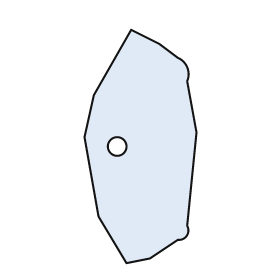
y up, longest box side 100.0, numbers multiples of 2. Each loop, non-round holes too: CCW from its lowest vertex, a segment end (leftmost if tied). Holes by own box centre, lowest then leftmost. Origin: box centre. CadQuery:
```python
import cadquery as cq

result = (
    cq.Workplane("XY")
    .moveTo(-6.0, -50.0)
    .lineTo(4.0, -48.0)
    .lineTo(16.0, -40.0)
    .threePointArc((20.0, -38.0), (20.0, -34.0))
    .lineTo(24.0, 6.0)
    .lineTo(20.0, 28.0)
    .threePointArc((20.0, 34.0), (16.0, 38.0))
    .lineTo(8.0, 44.0)
    .lineTo(-4.0, 50.0)
    .lineTo(-20.0, 22.0)
    .lineTo(-24.0, 4.0)
    .lineTo(-18.0, -30.0)
    .close()
    .moveTo(-10.0, 0.0)
    .circle(4.0)
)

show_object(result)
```